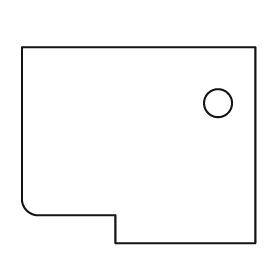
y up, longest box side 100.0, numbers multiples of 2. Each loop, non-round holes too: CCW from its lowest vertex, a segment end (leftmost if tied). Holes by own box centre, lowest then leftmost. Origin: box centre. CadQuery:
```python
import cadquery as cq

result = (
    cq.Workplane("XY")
    .moveTo(-10.0, -42.0)
    .lineTo(50.0, -42.0)
    .lineTo(50.0, 42.0)
    .lineTo(-50.0, 42.0)
    .lineTo(-50.0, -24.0)
    .threePointArc((-48.0, -28.0), (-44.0, -30.0))
    .lineTo(-10.0, -30.0)
    .close()
    .moveTo(34.0, 18.0)
    .circle(6.0)
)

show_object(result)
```